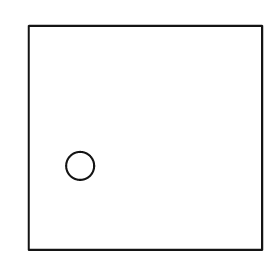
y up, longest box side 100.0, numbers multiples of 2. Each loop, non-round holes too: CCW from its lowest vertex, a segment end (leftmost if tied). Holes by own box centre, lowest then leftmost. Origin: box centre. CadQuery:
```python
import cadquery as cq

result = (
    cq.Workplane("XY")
    .moveTo(-50.0, -48.0)
    .lineTo(50.0, -48.0)
    .lineTo(50.0, 48.0)
    .lineTo(-50.0, 48.0)
    .close()
    .moveTo(-28.0, -12.0)
    .circle(6.0)
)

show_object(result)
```